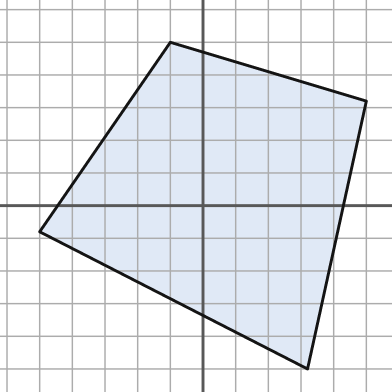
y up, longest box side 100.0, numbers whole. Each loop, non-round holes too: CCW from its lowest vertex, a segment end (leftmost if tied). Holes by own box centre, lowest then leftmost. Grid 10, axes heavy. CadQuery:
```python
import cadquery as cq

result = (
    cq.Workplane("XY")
    .moveTo(32.0, -50.0)
    .lineTo(50.0, 32.0)
    .lineTo(-10.0, 50.0)
    .lineTo(-50.0, -8.0)
    .close()
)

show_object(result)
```